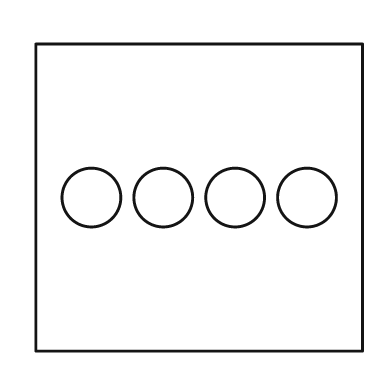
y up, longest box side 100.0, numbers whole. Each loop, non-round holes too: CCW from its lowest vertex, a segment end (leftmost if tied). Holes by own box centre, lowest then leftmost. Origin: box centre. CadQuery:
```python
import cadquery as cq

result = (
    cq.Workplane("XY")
    .moveTo(-50.0, -47.0)
    .lineTo(50.0, -47.0)
    .lineTo(50.0, 47.0)
    .lineTo(-50.0, 47.0)
    .close()
    .moveTo(-33.0, 0.0)
    .circle(9.0)
    .moveTo(-11.0, 0.0)
    .circle(9.0)
    .moveTo(11.0, 0.0)
    .circle(9.0)
    .moveTo(33.0, 0.0)
    .circle(9.0)
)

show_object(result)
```